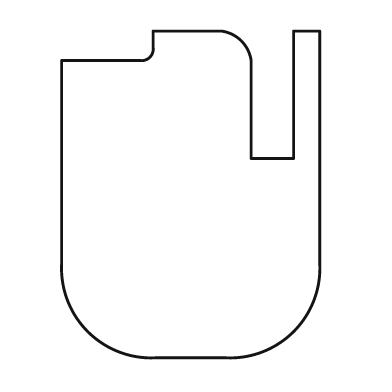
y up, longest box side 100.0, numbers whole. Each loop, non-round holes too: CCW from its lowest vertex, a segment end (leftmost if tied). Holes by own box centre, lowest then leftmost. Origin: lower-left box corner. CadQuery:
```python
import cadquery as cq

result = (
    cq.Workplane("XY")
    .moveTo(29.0, 0.0)
    .lineTo(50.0, 0.0)
    .threePointArc((71.0, 8.0), (79.0, 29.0))
    .lineTo(79.0, 100.0)
    .lineTo(71.0, 100.0)
    .lineTo(71.0, 61.0)
    .lineTo(58.0, 61.0)
    .lineTo(58.0, 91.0)
    .threePointArc((55.0, 97.0), (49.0, 100.0))
    .lineTo(28.0, 100.0)
    .lineTo(28.0, 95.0)
    .threePointArc((27.0, 92.0), (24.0, 91.0))
    .lineTo(0.0, 91.0)
    .lineTo(0.0, 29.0)
    .threePointArc((8.0, 8.0), (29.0, 0.0))
    .close()
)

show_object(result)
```